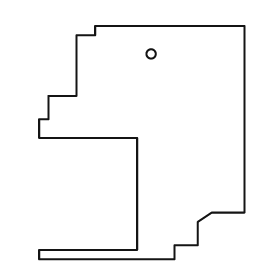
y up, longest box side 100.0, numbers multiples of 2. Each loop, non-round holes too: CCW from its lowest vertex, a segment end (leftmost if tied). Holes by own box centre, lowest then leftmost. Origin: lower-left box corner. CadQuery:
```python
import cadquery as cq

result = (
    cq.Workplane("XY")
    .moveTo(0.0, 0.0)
    .lineTo(58.0, 0.0)
    .lineTo(58.0, 6.0)
    .lineTo(68.0, 6.0)
    .lineTo(68.0, 16.0)
    .lineTo(74.0, 20.0)
    .lineTo(88.0, 20.0)
    .lineTo(88.0, 100.0)
    .lineTo(24.0, 100.0)
    .lineTo(24.0, 96.0)
    .lineTo(16.0, 96.0)
    .lineTo(16.0, 70.0)
    .lineTo(4.0, 70.0)
    .lineTo(4.0, 60.0)
    .lineTo(0.0, 60.0)
    .lineTo(0.0, 52.0)
    .lineTo(42.0, 52.0)
    .lineTo(42.0, 4.0)
    .lineTo(0.0, 4.0)
    .close()
    .moveTo(48.0, 88.0)
    .circle(2.0)
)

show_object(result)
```